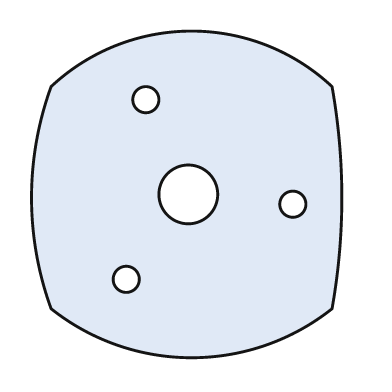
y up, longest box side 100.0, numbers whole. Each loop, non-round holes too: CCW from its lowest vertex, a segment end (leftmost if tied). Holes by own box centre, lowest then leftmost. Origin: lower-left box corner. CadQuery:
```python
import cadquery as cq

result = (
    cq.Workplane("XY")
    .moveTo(6.0, 15.0)
    .threePointArc((49.0, 0.0), (92.0, 15.0))
    .threePointArc((95.0, 49.0), (92.0, 83.0))
    .threePointArc((49.0, 100.0), (6.0, 83.0))
    .threePointArc((0.0, 49.0), (6.0, 15.0))
    .close()
    .moveTo(29.0, 24.0)
    .circle(4.0)
    .moveTo(80.0, 47.0)
    .circle(4.0)
    .moveTo(48.0, 50.0)
    .circle(9.0)
    .moveTo(35.0, 79.0)
    .circle(4.0)
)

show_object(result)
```